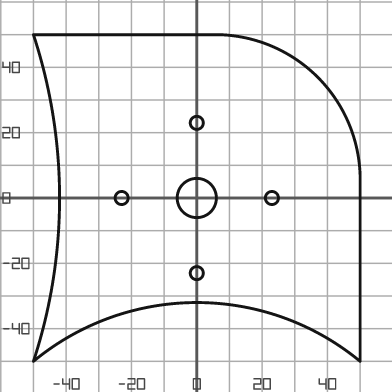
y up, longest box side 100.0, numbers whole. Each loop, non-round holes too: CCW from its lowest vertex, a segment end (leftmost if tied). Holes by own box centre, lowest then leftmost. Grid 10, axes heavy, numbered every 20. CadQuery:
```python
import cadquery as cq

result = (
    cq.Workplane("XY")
    .moveTo(-50.0, -50.0)
    .threePointArc((0.0, -32.0), (50.0, -50.0))
    .lineTo(50.0, 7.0)
    .threePointArc((37.0, 37.0), (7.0, 50.0))
    .lineTo(-50.0, 50.0)
    .threePointArc((-42.0, 0.0), (-50.0, -50.0))
    .close()
    .moveTo(0.0, -23.0)
    .circle(2.0)
    .moveTo(-23.0, 0.0)
    .circle(2.0)
    .moveTo(0.0, 0.0)
    .circle(6.0)
    .moveTo(23.0, 0.0)
    .circle(2.0)
    .moveTo(0.0, 23.0)
    .circle(2.0)
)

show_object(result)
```